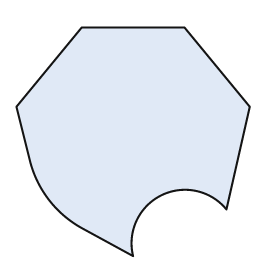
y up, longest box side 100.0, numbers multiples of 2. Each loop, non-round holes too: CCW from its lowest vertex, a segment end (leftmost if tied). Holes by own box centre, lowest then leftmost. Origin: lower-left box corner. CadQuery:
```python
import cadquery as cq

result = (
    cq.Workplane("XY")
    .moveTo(50.0, 0.0)
    .threePointArc((62.0, 26.0), (90.0, 20.0))
    .lineTo(100.0, 64.0)
    .lineTo(72.0, 98.0)
    .lineTo(28.0, 98.0)
    .lineTo(0.0, 64.0)
    .lineTo(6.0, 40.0)
    .threePointArc((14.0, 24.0), (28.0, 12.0))
    .close()
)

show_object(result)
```